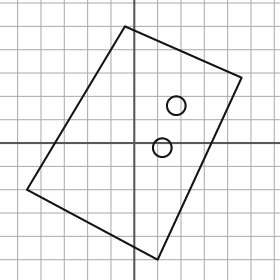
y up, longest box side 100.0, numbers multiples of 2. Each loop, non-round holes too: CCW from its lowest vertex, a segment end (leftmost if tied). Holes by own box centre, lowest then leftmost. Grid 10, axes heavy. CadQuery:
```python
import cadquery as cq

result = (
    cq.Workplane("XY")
    .moveTo(10.0, -50.0)
    .lineTo(46.0, 28.0)
    .lineTo(-4.0, 50.0)
    .lineTo(-46.0, -20.0)
    .close()
    .moveTo(12.0, -2.0)
    .circle(4.0)
    .moveTo(18.0, 16.0)
    .circle(4.0)
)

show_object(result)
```